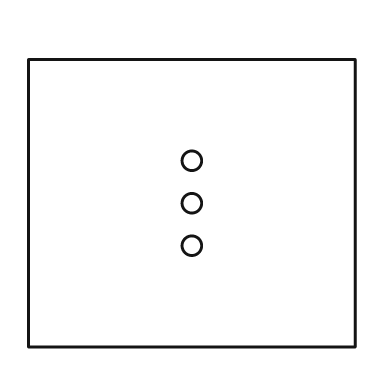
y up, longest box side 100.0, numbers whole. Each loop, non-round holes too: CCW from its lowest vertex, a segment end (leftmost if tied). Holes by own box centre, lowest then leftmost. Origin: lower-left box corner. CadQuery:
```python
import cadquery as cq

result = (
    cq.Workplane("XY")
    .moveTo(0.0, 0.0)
    .lineTo(100.0, 0.0)
    .lineTo(100.0, 88.0)
    .lineTo(0.0, 88.0)
    .close()
    .moveTo(50.0, 31.0)
    .circle(3.0)
    .moveTo(50.0, 44.0)
    .circle(3.0)
    .moveTo(50.0, 57.0)
    .circle(3.0)
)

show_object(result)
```